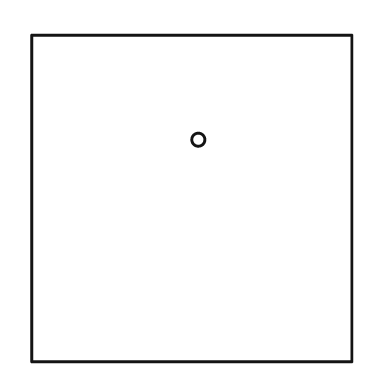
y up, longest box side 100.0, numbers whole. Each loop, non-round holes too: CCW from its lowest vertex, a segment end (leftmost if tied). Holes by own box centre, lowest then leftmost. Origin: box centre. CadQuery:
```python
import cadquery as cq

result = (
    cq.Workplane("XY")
    .moveTo(-49.0, -50.0)
    .lineTo(49.0, -50.0)
    .lineTo(49.0, 50.0)
    .lineTo(-49.0, 50.0)
    .close()
    .moveTo(2.0, 18.0)
    .circle(2.0)
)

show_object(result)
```